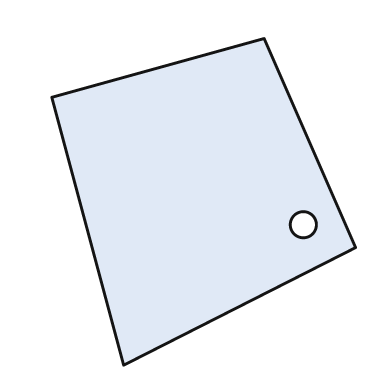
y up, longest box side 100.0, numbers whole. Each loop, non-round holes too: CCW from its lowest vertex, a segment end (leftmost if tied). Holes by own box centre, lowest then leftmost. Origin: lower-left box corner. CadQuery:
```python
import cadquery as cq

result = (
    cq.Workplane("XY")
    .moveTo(22.0, 0.0)
    .lineTo(93.0, 36.0)
    .lineTo(65.0, 100.0)
    .lineTo(0.0, 82.0)
    .close()
    .moveTo(77.0, 43.0)
    .circle(4.0)
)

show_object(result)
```